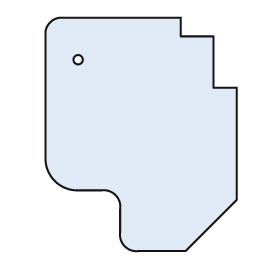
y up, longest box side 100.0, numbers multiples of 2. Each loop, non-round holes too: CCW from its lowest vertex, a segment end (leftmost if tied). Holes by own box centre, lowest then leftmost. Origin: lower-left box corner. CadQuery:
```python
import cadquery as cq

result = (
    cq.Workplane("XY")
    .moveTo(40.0, 0.0)
    .lineTo(60.0, 0.0)
    .lineTo(82.0, 22.0)
    .lineTo(82.0, 70.0)
    .lineTo(72.0, 70.0)
    .lineTo(72.0, 92.0)
    .lineTo(58.0, 92.0)
    .lineTo(58.0, 100.0)
    .lineTo(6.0, 100.0)
    .threePointArc((2.0, 98.0), (0.0, 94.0))
    .lineTo(0.0, 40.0)
    .threePointArc((4.0, 30.0), (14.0, 26.0))
    .lineTo(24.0, 26.0)
    .threePointArc((30.0, 24.0), (32.0, 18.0))
    .lineTo(32.0, 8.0)
    .threePointArc((34.0, 2.0), (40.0, 0.0))
    .close()
    .moveTo(14.0, 82.0)
    .circle(2.0)
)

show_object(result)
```